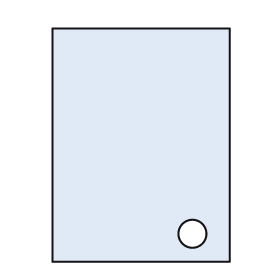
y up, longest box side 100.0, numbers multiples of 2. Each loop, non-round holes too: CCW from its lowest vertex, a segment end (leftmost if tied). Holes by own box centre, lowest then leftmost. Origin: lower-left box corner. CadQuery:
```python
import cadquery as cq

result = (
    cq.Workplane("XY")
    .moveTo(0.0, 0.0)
    .lineTo(76.0, 0.0)
    .lineTo(76.0, 100.0)
    .lineTo(0.0, 100.0)
    .close()
    .moveTo(60.0, 12.0)
    .circle(6.0)
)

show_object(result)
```